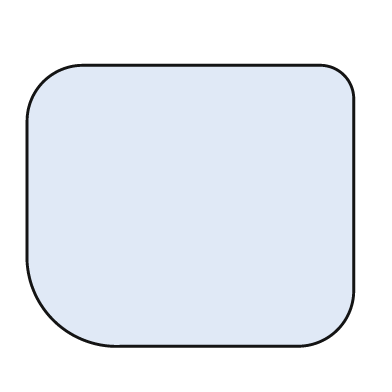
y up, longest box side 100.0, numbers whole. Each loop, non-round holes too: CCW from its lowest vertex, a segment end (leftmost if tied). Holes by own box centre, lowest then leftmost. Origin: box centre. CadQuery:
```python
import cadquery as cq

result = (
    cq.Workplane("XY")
    .moveTo(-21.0, -43.0)
    .lineTo(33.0, -43.0)
    .threePointArc((45.0, -38.0), (50.0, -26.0))
    .lineTo(50.0, 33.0)
    .threePointArc((47.0, 40.0), (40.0, 43.0))
    .lineTo(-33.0, 43.0)
    .threePointArc((-45.0, 38.0), (-50.0, 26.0))
    .lineTo(-50.0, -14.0)
    .threePointArc((-42.0, -35.0), (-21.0, -43.0))
    .close()
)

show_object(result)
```